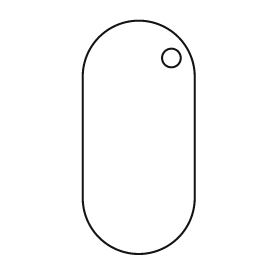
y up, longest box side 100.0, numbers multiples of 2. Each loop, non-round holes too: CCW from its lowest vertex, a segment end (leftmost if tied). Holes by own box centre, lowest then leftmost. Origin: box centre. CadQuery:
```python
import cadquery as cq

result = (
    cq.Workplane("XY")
    .moveTo(-24.0, -26.0)
    .threePointArc((0.0, -50.0), (24.0, -26.0))
    .lineTo(24.0, 26.0)
    .threePointArc((0.0, 50.0), (-24.0, 26.0))
    .close()
    .moveTo(14.0, 34.0)
    .circle(4.0)
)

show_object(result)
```